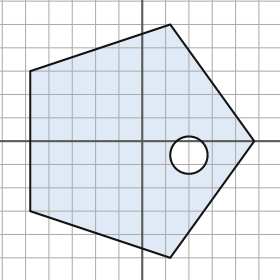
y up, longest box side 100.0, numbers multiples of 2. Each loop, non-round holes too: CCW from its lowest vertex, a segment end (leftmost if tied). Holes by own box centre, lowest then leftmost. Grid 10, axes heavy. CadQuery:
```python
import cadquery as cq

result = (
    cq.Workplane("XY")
    .moveTo(12.0, -50.0)
    .lineTo(48.0, 0.0)
    .lineTo(12.0, 50.0)
    .lineTo(-48.0, 30.0)
    .lineTo(-48.0, -30.0)
    .close()
    .moveTo(20.0, -6.0)
    .circle(8.0)
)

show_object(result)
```